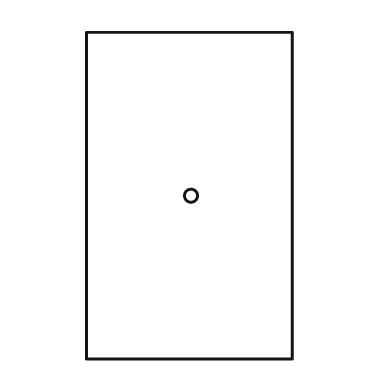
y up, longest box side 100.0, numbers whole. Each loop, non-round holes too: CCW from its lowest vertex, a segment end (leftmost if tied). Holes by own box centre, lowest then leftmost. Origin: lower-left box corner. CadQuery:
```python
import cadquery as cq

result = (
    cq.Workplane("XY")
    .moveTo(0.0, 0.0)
    .lineTo(63.0, 0.0)
    .lineTo(63.0, 100.0)
    .lineTo(0.0, 100.0)
    .close()
    .moveTo(32.0, 50.0)
    .circle(2.0)
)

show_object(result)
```